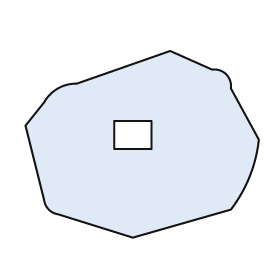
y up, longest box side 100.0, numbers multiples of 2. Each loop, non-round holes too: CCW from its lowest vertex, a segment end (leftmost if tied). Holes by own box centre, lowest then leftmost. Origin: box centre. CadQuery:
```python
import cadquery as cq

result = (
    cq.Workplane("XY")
    .moveTo(-4.0, -40.0)
    .lineTo(38.0, -28.0)
    .threePointArc((46.0, -14.0), (50.0, 2.0))
    .lineTo(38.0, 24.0)
    .threePointArc((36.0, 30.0), (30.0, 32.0))
    .lineTo(12.0, 40.0)
    .lineTo(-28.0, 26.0)
    .threePointArc((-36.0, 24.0), (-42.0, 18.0))
    .lineTo(-50.0, 8.0)
    .lineTo(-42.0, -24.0)
    .threePointArc((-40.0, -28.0), (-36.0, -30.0))
    .close()
    .moveTo(-12.0, -2.0)
    .lineTo(4.0, -2.0)
    .lineTo(4.0, 10.0)
    .lineTo(-12.0, 10.0)
    .close()
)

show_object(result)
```